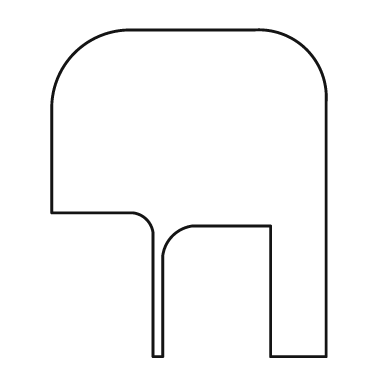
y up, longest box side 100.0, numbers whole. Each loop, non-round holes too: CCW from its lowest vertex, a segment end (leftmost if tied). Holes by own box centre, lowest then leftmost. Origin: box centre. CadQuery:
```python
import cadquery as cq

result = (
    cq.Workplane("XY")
    .moveTo(-11.0, -50.0)
    .lineTo(-8.0, -50.0)
    .lineTo(-8.0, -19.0)
    .threePointArc((-5.0, -13.0), (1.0, -10.0))
    .lineTo(25.0, -10.0)
    .lineTo(25.0, -50.0)
    .lineTo(42.0, -50.0)
    .lineTo(42.0, 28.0)
    .threePointArc((36.0, 44.0), (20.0, 50.0))
    .lineTo(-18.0, 50.0)
    .threePointArc((-35.0, 43.0), (-42.0, 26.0))
    .lineTo(-42.0, -6.0)
    .lineTo(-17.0, -6.0)
    .threePointArc((-13.0, -8.0), (-11.0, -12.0))
    .close()
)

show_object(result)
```